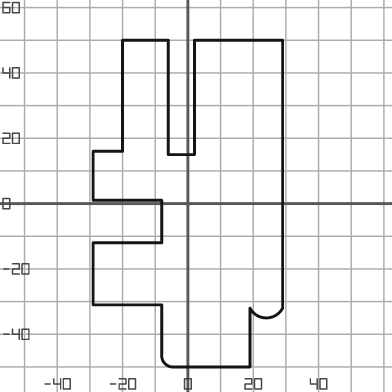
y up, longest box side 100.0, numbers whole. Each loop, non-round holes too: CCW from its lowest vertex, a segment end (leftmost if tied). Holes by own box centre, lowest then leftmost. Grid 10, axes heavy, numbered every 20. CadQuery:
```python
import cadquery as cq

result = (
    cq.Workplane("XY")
    .moveTo(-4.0, -50.0)
    .lineTo(19.0, -50.0)
    .lineTo(19.0, -32.0)
    .threePointArc((24.0, -35.0), (29.0, -32.0))
    .lineTo(29.0, 50.0)
    .lineTo(2.0, 50.0)
    .lineTo(2.0, 15.0)
    .lineTo(-6.0, 15.0)
    .lineTo(-6.0, 50.0)
    .lineTo(-20.0, 50.0)
    .lineTo(-20.0, 16.0)
    .lineTo(-29.0, 16.0)
    .lineTo(-29.0, 1.0)
    .lineTo(-8.0, 1.0)
    .lineTo(-8.0, -12.0)
    .lineTo(-29.0, -12.0)
    .lineTo(-29.0, -31.0)
    .lineTo(-8.0, -31.0)
    .lineTo(-8.0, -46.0)
    .threePointArc((-7.0, -49.0), (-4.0, -50.0))
    .close()
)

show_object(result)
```